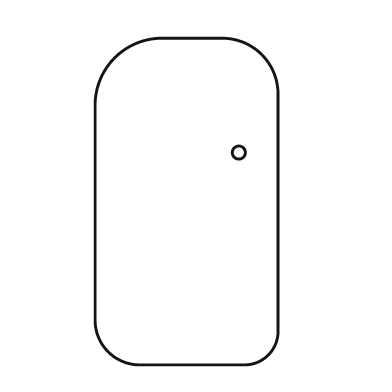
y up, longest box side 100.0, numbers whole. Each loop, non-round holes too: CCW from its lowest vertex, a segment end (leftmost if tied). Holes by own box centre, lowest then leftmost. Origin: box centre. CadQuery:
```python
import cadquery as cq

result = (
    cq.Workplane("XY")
    .moveTo(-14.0, -50.0)
    .lineTo(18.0, -50.0)
    .threePointArc((25.0, -47.0), (28.0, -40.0))
    .lineTo(28.0, 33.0)
    .threePointArc((23.0, 45.0), (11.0, 50.0))
    .lineTo(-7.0, 50.0)
    .threePointArc((-22.0, 44.0), (-28.0, 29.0))
    .lineTo(-28.0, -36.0)
    .threePointArc((-24.0, -46.0), (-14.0, -50.0))
    .close()
    .moveTo(16.0, 15.0)
    .circle(2.0)
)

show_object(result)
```